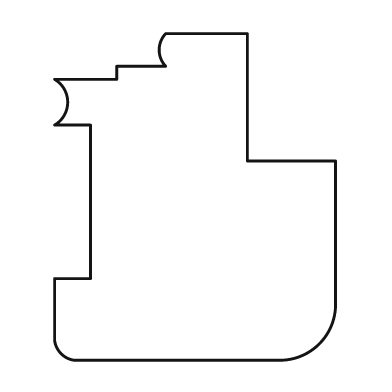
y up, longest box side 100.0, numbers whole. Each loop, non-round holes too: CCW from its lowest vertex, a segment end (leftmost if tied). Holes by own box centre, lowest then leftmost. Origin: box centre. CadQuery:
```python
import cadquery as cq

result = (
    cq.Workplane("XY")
    .moveTo(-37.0, -50.0)
    .lineTo(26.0, -50.0)
    .threePointArc((38.0, -45.0), (43.0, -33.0))
    .lineTo(43.0, 11.0)
    .lineTo(16.0, 11.0)
    .lineTo(16.0, 50.0)
    .lineTo(-9.0, 50.0)
    .threePointArc((-11.0, 45.0), (-9.0, 40.0))
    .lineTo(-24.0, 40.0)
    .lineTo(-24.0, 36.0)
    .lineTo(-43.0, 36.0)
    .threePointArc((-39.0, 29.0), (-43.0, 22.0))
    .lineTo(-32.0, 22.0)
    .lineTo(-32.0, -25.0)
    .lineTo(-43.0, -25.0)
    .lineTo(-43.0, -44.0)
    .threePointArc((-41.0, -48.0), (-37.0, -50.0))
    .close()
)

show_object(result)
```